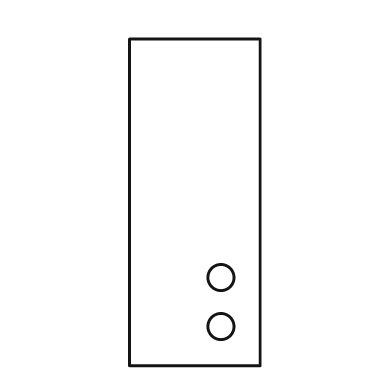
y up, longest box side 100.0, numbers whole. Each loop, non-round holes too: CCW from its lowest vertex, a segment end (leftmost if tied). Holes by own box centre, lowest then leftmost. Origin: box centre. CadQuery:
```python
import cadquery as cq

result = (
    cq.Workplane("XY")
    .moveTo(-20.0, -50.0)
    .lineTo(20.0, -50.0)
    .lineTo(20.0, 50.0)
    .lineTo(-20.0, 50.0)
    .close()
    .moveTo(8.0, -38.0)
    .circle(4.0)
    .moveTo(8.0, -23.0)
    .circle(4.0)
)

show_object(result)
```